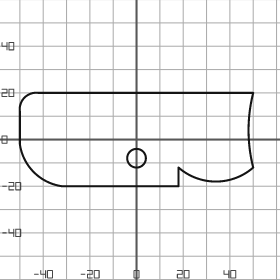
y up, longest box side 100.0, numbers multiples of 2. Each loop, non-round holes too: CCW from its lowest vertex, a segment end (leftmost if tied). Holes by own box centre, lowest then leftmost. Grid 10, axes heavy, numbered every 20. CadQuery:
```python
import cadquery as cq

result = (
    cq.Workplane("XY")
    .moveTo(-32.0, -20.0)
    .lineTo(18.0, -20.0)
    .lineTo(18.0, -12.0)
    .threePointArc((34.0, -18.0), (50.0, -12.0))
    .threePointArc((48.0, 4.0), (50.0, 20.0))
    .lineTo(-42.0, 20.0)
    .threePointArc((-48.0, 18.0), (-50.0, 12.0))
    .lineTo(-50.0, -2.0)
    .threePointArc((-44.0, -14.0), (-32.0, -20.0))
    .close()
    .moveTo(0.0, -8.0)
    .circle(4.0)
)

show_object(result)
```